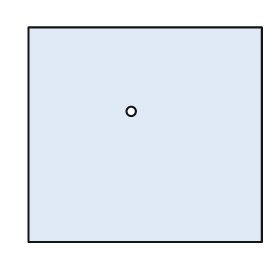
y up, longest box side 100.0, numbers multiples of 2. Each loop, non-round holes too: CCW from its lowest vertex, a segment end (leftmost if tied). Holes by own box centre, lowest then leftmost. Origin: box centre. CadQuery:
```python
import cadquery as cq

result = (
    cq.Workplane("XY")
    .moveTo(-50.0, -46.0)
    .lineTo(50.0, -46.0)
    .lineTo(50.0, 46.0)
    .lineTo(-50.0, 46.0)
    .close()
    .moveTo(-6.0, 10.0)
    .circle(2.0)
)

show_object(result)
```